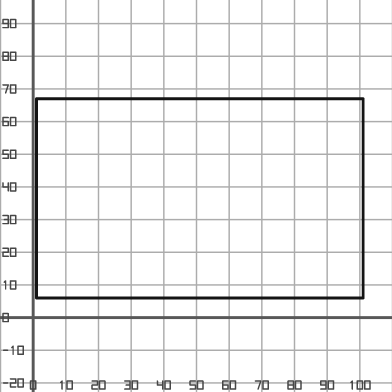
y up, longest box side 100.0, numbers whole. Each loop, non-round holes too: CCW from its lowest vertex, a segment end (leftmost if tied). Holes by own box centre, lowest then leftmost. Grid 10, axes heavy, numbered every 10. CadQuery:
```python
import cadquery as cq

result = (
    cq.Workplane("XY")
    .moveTo(1.0, 6.0)
    .lineTo(101.0, 6.0)
    .lineTo(101.0, 67.0)
    .lineTo(1.0, 67.0)
    .close()
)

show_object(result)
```